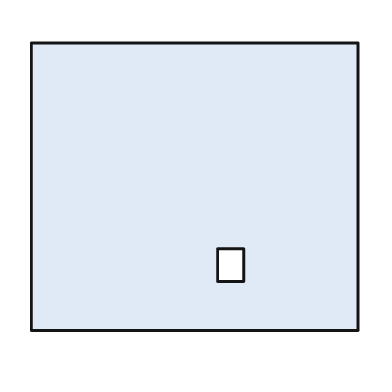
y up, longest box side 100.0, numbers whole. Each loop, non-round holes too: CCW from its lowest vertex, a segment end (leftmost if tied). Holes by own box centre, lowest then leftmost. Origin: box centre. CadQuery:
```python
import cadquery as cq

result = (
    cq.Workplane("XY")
    .moveTo(-50.0, -44.0)
    .lineTo(50.0, -44.0)
    .lineTo(50.0, 44.0)
    .lineTo(-50.0, 44.0)
    .close()
    .moveTo(7.0, -29.0)
    .lineTo(15.0, -29.0)
    .lineTo(15.0, -19.0)
    .lineTo(7.0, -19.0)
    .close()
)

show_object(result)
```